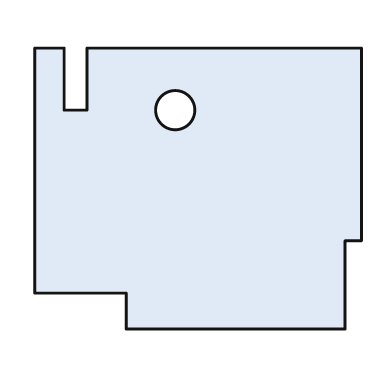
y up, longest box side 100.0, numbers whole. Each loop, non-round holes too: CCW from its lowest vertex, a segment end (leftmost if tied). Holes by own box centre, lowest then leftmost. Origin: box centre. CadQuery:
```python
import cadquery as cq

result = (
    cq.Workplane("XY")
    .moveTo(-22.0, -43.0)
    .lineTo(45.0, -43.0)
    .lineTo(45.0, -16.0)
    .lineTo(50.0, -16.0)
    .lineTo(50.0, 43.0)
    .lineTo(-34.0, 43.0)
    .lineTo(-34.0, 24.0)
    .lineTo(-41.0, 24.0)
    .lineTo(-41.0, 43.0)
    .lineTo(-50.0, 43.0)
    .lineTo(-50.0, -32.0)
    .lineTo(-22.0, -32.0)
    .close()
    .moveTo(-7.0, 24.0)
    .circle(6.0)
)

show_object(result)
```